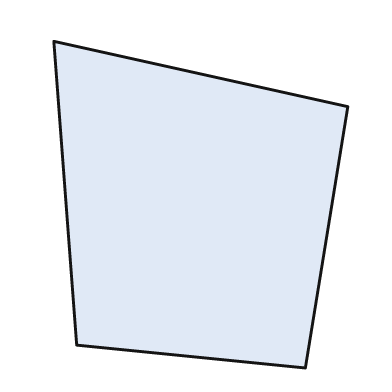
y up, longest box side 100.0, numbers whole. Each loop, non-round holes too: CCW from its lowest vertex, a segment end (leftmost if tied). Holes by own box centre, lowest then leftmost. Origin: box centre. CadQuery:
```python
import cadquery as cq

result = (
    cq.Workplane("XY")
    .moveTo(32.0, -50.0)
    .lineTo(45.0, 30.0)
    .lineTo(-45.0, 50.0)
    .lineTo(-38.0, -43.0)
    .close()
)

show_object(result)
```